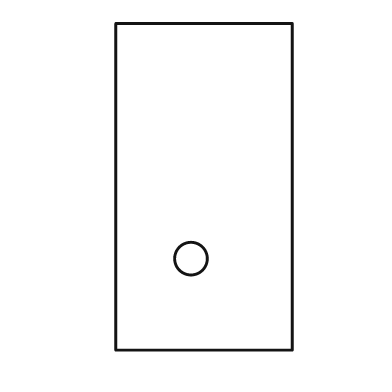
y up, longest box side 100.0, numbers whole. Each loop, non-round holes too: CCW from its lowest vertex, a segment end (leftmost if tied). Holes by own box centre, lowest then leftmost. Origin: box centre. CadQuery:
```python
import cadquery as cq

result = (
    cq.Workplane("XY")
    .moveTo(-27.0, -50.0)
    .lineTo(27.0, -50.0)
    .lineTo(27.0, 50.0)
    .lineTo(-27.0, 50.0)
    .close()
    .moveTo(-4.0, -22.0)
    .circle(5.0)
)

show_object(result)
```